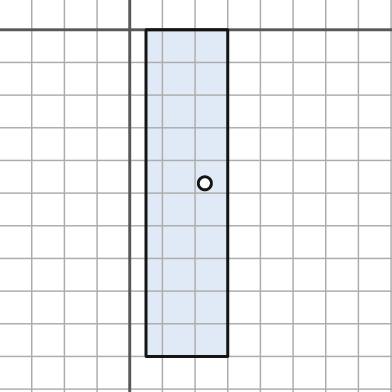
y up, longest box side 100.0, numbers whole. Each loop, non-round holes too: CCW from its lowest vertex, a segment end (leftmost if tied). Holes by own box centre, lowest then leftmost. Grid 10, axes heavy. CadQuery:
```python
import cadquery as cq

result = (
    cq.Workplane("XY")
    .moveTo(5.0, -100.0)
    .lineTo(30.0, -100.0)
    .lineTo(30.0, 0.0)
    .lineTo(5.0, 0.0)
    .close()
    .moveTo(23.0, -47.0)
    .circle(2.0)
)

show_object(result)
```